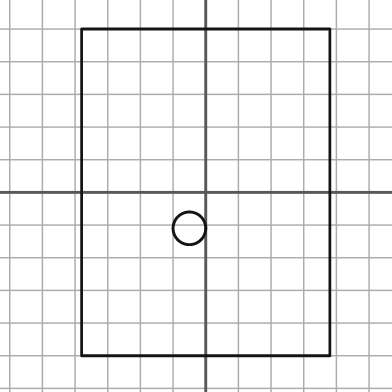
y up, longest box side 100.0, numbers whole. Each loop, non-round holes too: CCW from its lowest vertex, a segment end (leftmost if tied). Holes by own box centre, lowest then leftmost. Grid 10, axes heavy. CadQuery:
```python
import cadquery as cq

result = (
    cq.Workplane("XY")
    .moveTo(-38.0, -50.0)
    .lineTo(38.0, -50.0)
    .lineTo(38.0, 50.0)
    .lineTo(-38.0, 50.0)
    .close()
    .moveTo(-5.0, -11.0)
    .circle(5.0)
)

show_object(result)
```